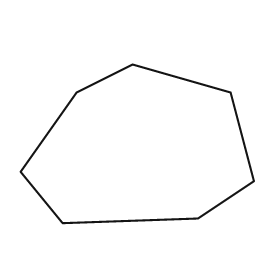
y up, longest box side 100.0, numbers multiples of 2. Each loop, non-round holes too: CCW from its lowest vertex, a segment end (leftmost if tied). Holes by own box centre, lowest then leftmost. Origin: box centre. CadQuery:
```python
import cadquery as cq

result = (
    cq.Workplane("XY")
    .moveTo(-32.0, -34.0)
    .lineTo(26.0, -32.0)
    .lineTo(50.0, -16.0)
    .lineTo(40.0, 22.0)
    .lineTo(-2.0, 34.0)
    .lineTo(-26.0, 22.0)
    .lineTo(-50.0, -12.0)
    .close()
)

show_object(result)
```